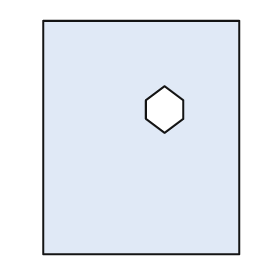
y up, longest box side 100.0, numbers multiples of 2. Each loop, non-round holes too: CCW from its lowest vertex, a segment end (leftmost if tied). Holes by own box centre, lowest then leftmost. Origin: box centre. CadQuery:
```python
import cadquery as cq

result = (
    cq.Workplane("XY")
    .moveTo(-42.0, -50.0)
    .lineTo(42.0, -50.0)
    .lineTo(42.0, 50.0)
    .lineTo(-42.0, 50.0)
    .close()
    .moveTo(10.0, 2.0)
    .lineTo(18.0, 8.0)
    .lineTo(18.0, 16.0)
    .lineTo(10.0, 22.0)
    .lineTo(2.0, 16.0)
    .lineTo(2.0, 8.0)
    .close()
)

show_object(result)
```